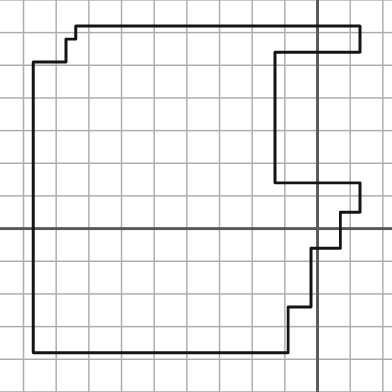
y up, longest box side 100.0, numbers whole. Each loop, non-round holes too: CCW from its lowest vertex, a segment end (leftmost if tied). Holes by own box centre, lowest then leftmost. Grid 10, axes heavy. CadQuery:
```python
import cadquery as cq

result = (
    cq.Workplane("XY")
    .moveTo(-87.0, -38.0)
    .lineTo(-9.0, -38.0)
    .lineTo(-9.0, -24.0)
    .lineTo(-2.0, -24.0)
    .lineTo(-2.0, -6.0)
    .lineTo(7.0, -6.0)
    .lineTo(7.0, 5.0)
    .lineTo(13.0, 5.0)
    .lineTo(13.0, 14.0)
    .lineTo(-13.0, 14.0)
    .lineTo(-13.0, 54.0)
    .lineTo(13.0, 54.0)
    .lineTo(13.0, 62.0)
    .lineTo(-74.0, 62.0)
    .lineTo(-74.0, 58.0)
    .lineTo(-77.0, 58.0)
    .lineTo(-77.0, 51.0)
    .lineTo(-87.0, 51.0)
    .close()
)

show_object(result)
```